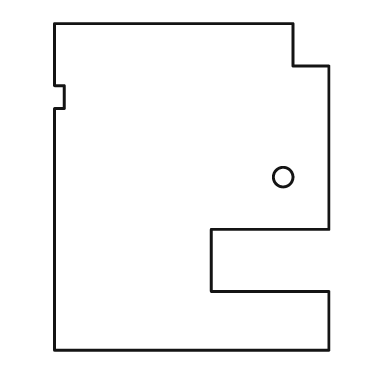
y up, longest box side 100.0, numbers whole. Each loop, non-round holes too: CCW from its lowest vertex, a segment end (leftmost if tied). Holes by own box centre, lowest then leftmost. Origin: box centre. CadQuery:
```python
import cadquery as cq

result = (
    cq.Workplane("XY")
    .moveTo(-42.0, -50.0)
    .lineTo(42.0, -50.0)
    .lineTo(42.0, -32.0)
    .lineTo(6.0, -32.0)
    .lineTo(6.0, -13.0)
    .lineTo(42.0, -13.0)
    .lineTo(42.0, 37.0)
    .lineTo(31.0, 37.0)
    .lineTo(31.0, 50.0)
    .lineTo(-42.0, 50.0)
    .lineTo(-42.0, 31.0)
    .lineTo(-39.0, 31.0)
    .lineTo(-39.0, 24.0)
    .lineTo(-42.0, 24.0)
    .close()
    .moveTo(28.0, 3.0)
    .circle(3.0)
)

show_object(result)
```